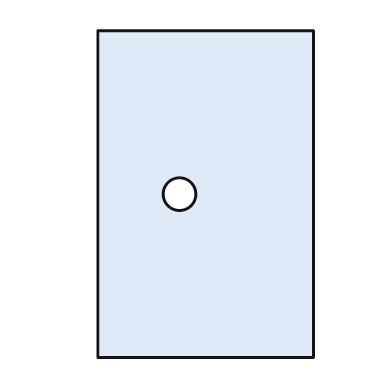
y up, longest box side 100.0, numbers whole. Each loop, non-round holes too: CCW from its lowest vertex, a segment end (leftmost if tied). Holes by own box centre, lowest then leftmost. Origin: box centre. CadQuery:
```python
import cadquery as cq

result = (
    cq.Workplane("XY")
    .moveTo(-33.0, -50.0)
    .lineTo(33.0, -50.0)
    .lineTo(33.0, 50.0)
    .lineTo(-33.0, 50.0)
    .close()
    .moveTo(-8.0, 0.0)
    .circle(5.0)
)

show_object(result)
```